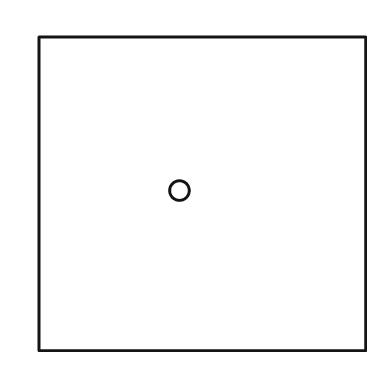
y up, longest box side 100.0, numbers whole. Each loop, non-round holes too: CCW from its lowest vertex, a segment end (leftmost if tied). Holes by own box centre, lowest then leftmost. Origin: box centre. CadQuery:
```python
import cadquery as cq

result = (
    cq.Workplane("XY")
    .moveTo(-50.0, -48.0)
    .lineTo(50.0, -48.0)
    .lineTo(50.0, 48.0)
    .lineTo(-50.0, 48.0)
    .close()
    .moveTo(-7.0, 1.0)
    .circle(3.0)
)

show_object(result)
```